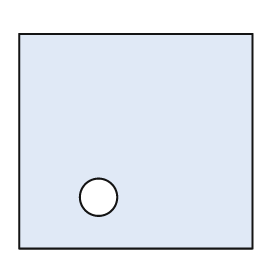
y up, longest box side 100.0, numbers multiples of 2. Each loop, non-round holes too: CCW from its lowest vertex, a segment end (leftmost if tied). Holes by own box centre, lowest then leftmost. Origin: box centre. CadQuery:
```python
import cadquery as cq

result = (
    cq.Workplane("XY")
    .moveTo(-50.0, -46.0)
    .lineTo(50.0, -46.0)
    .lineTo(50.0, 46.0)
    .lineTo(-50.0, 46.0)
    .close()
    .moveTo(-16.0, -24.0)
    .circle(8.0)
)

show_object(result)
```